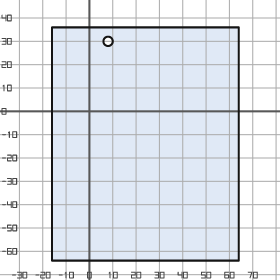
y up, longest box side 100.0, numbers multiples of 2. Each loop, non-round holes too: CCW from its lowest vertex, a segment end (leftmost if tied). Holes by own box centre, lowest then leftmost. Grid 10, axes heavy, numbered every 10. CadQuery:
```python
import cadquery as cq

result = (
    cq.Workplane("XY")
    .moveTo(-16.0, -64.0)
    .lineTo(64.0, -64.0)
    .lineTo(64.0, 36.0)
    .lineTo(-16.0, 36.0)
    .close()
    .moveTo(8.0, 30.0)
    .circle(2.0)
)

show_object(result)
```